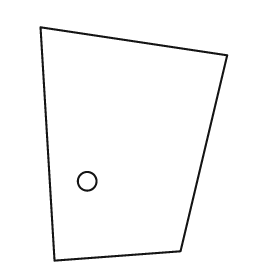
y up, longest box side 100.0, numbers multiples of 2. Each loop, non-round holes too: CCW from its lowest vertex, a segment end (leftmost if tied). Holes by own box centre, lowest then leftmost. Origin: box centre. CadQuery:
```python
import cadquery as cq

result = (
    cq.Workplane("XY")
    .moveTo(-34.0, -50.0)
    .lineTo(20.0, -46.0)
    .lineTo(40.0, 38.0)
    .lineTo(-40.0, 50.0)
    .close()
    .moveTo(-20.0, -16.0)
    .circle(4.0)
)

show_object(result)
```